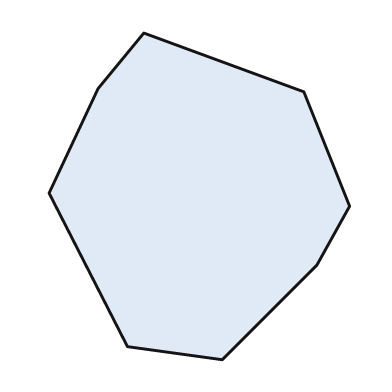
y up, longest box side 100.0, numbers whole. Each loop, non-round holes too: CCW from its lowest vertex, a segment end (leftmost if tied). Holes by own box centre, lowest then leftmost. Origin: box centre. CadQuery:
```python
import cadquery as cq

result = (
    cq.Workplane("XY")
    .moveTo(7.0, -50.0)
    .lineTo(36.0, -21.0)
    .lineTo(46.0, -3.0)
    .lineTo(32.0, 32.0)
    .lineTo(-17.0, 50.0)
    .lineTo(-31.0, 33.0)
    .lineTo(-46.0, 1.0)
    .lineTo(-22.0, -46.0)
    .close()
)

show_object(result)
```